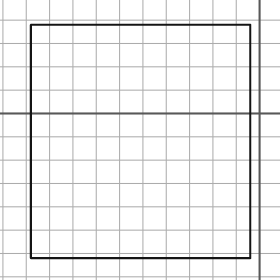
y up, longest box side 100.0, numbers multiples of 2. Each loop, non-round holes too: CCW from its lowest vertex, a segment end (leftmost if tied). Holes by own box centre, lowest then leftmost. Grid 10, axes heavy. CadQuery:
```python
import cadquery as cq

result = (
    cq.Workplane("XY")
    .moveTo(-98.0, -62.0)
    .lineTo(-4.0, -62.0)
    .lineTo(-4.0, 38.0)
    .lineTo(-98.0, 38.0)
    .close()
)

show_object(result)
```